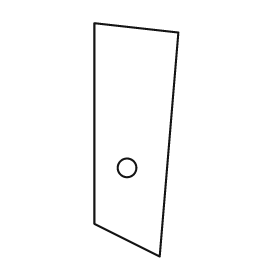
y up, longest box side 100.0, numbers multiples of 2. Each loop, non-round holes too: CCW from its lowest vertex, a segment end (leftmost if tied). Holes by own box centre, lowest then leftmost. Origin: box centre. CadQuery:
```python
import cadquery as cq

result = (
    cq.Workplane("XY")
    .moveTo(10.0, -50.0)
    .lineTo(18.0, 46.0)
    .lineTo(-18.0, 50.0)
    .lineTo(-18.0, -36.0)
    .close()
    .moveTo(-4.0, -12.0)
    .circle(4.0)
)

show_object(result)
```